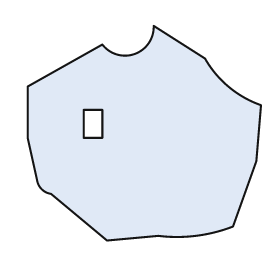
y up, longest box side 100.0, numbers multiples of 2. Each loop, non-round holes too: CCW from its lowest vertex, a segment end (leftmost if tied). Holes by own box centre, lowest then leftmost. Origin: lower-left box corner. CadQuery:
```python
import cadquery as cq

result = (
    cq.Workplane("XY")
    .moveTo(34.0, 0.0)
    .lineTo(56.0, 2.0)
    .threePointArc((72.0, 2.0), (88.0, 6.0))
    .lineTo(98.0, 34.0)
    .lineTo(100.0, 58.0)
    .threePointArc((86.0, 66.0), (76.0, 78.0))
    .lineTo(54.0, 92.0)
    .threePointArc((46.0, 80.0), (32.0, 84.0))
    .lineTo(0.0, 66.0)
    .lineTo(0.0, 44.0)
    .lineTo(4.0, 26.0)
    .threePointArc((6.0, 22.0), (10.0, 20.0))
    .close()
    .moveTo(24.0, 44.0)
    .lineTo(32.0, 44.0)
    .lineTo(32.0, 56.0)
    .lineTo(24.0, 56.0)
    .close()
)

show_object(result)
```